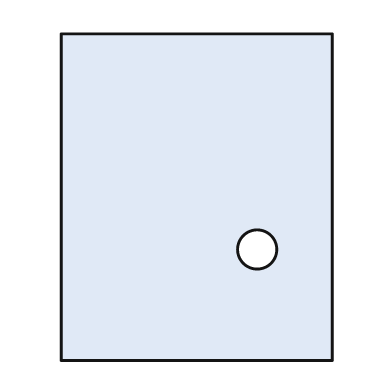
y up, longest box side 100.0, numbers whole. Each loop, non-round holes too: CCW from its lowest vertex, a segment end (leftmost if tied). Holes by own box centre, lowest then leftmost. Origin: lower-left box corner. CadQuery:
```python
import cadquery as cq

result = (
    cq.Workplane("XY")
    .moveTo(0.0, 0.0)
    .lineTo(83.0, 0.0)
    .lineTo(83.0, 100.0)
    .lineTo(0.0, 100.0)
    .close()
    .moveTo(60.0, 34.0)
    .circle(6.0)
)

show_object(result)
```